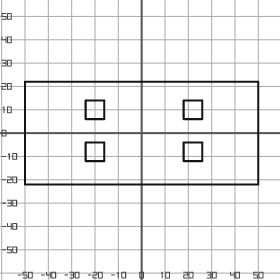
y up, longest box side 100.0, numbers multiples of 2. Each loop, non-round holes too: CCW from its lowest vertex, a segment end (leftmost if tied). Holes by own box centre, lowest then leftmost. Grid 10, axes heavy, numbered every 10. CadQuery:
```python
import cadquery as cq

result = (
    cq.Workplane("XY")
    .moveTo(-50.0, -22.0)
    .lineTo(50.0, -22.0)
    .lineTo(50.0, 22.0)
    .lineTo(-50.0, 22.0)
    .close()
    .moveTo(-24.0, -12.0)
    .lineTo(-16.0, -12.0)
    .lineTo(-16.0, -4.0)
    .lineTo(-24.0, -4.0)
    .close()
    .moveTo(18.0, -12.0)
    .lineTo(26.0, -12.0)
    .lineTo(26.0, -4.0)
    .lineTo(18.0, -4.0)
    .close()
    .moveTo(-24.0, 6.0)
    .lineTo(-16.0, 6.0)
    .lineTo(-16.0, 14.0)
    .lineTo(-24.0, 14.0)
    .close()
    .moveTo(18.0, 6.0)
    .lineTo(26.0, 6.0)
    .lineTo(26.0, 14.0)
    .lineTo(18.0, 14.0)
    .close()
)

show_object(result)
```